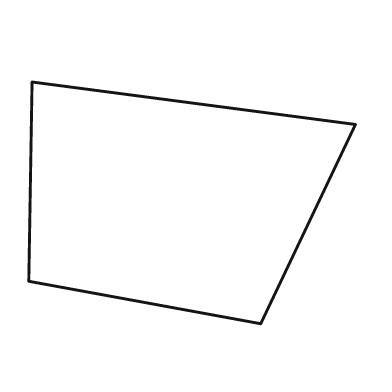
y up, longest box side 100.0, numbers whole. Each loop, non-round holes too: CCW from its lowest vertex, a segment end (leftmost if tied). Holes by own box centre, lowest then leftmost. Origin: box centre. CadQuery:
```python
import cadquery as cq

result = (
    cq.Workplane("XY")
    .moveTo(21.0, -37.0)
    .lineTo(50.0, 24.0)
    .lineTo(-49.0, 37.0)
    .lineTo(-50.0, -24.0)
    .close()
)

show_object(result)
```